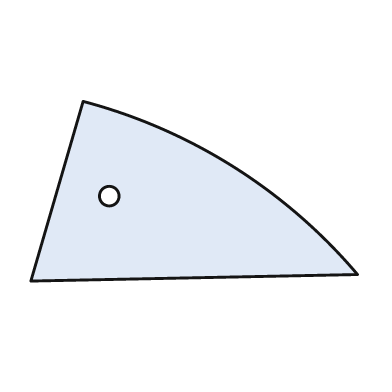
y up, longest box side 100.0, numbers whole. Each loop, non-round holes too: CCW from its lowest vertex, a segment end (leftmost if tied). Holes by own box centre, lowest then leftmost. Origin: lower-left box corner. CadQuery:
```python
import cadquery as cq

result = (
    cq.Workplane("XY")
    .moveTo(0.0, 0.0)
    .lineTo(100.0, 2.0)
    .threePointArc((62.0, 35.0), (16.0, 55.0))
    .close()
    .moveTo(24.0, 26.0)
    .circle(3.0)
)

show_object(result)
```